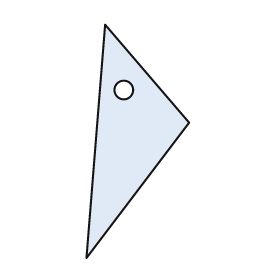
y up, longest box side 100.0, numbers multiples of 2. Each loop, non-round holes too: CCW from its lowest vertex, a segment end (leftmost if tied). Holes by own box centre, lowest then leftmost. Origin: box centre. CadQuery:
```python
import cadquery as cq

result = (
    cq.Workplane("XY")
    .moveTo(-22.0, -50.0)
    .lineTo(22.0, 8.0)
    .lineTo(-14.0, 50.0)
    .close()
    .moveTo(-6.0, 22.0)
    .circle(4.0)
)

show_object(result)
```